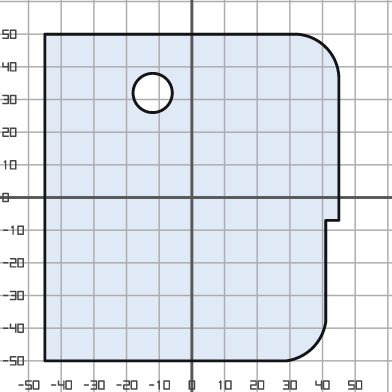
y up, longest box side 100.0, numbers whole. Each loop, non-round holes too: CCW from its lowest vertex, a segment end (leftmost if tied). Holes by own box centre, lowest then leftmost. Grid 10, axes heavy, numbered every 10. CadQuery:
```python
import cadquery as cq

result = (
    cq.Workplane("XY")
    .moveTo(-45.0, -50.0)
    .lineTo(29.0, -50.0)
    .threePointArc((37.0, -46.0), (41.0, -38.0))
    .lineTo(41.0, -7.0)
    .lineTo(45.0, -7.0)
    .lineTo(45.0, 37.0)
    .threePointArc((41.0, 46.0), (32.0, 50.0))
    .lineTo(-45.0, 50.0)
    .close()
    .moveTo(-12.0, 32.0)
    .circle(6.0)
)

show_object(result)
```